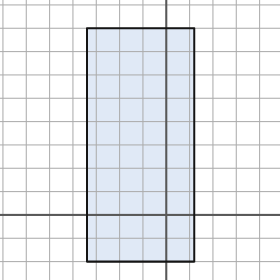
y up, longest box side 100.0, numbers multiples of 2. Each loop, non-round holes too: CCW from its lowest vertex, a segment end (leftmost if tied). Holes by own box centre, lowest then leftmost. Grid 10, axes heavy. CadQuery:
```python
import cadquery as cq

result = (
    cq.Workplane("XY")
    .moveTo(-34.0, -20.0)
    .lineTo(12.0, -20.0)
    .lineTo(12.0, 80.0)
    .lineTo(-34.0, 80.0)
    .close()
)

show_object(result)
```